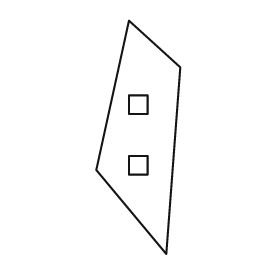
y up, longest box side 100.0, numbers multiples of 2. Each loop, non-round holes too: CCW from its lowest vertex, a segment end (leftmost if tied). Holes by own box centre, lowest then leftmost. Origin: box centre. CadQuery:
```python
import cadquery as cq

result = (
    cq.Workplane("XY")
    .moveTo(12.0, -50.0)
    .lineTo(18.0, 30.0)
    .lineTo(-4.0, 50.0)
    .lineTo(-18.0, -14.0)
    .close()
    .moveTo(-4.0, -16.0)
    .lineTo(4.0, -16.0)
    .lineTo(4.0, -8.0)
    .lineTo(-4.0, -8.0)
    .close()
    .moveTo(-4.0, 10.0)
    .lineTo(4.0, 10.0)
    .lineTo(4.0, 18.0)
    .lineTo(-4.0, 18.0)
    .close()
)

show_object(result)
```